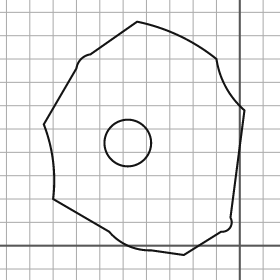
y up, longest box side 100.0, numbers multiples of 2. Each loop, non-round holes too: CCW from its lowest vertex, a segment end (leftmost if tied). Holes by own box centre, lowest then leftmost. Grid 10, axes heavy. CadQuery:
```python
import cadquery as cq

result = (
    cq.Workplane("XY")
    .moveTo(-24.0, -4.0)
    .lineTo(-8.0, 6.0)
    .threePointArc((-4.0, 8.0), (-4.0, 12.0))
    .lineTo(2.0, 58.0)
    .threePointArc((-6.0, 68.0), (-10.0, 80.0))
    .threePointArc((-26.0, 90.0), (-44.0, 96.0))
    .lineTo(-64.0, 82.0)
    .threePointArc((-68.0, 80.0), (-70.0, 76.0))
    .lineTo(-84.0, 52.0)
    .threePointArc((-80.0, 36.0), (-80.0, 20.0))
    .lineTo(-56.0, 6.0)
    .threePointArc((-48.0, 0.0), (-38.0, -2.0))
    .close()
    .moveTo(-48.0, 44.0)
    .circle(10.0)
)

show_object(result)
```